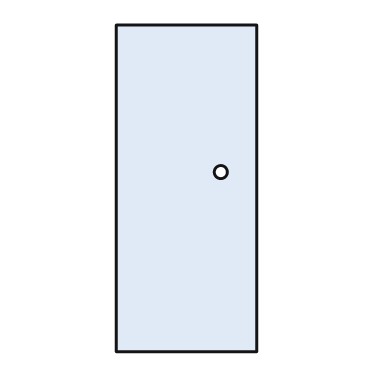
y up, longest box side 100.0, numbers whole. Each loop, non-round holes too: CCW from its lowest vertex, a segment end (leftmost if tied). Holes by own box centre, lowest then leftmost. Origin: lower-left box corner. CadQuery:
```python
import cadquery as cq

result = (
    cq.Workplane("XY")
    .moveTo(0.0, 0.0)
    .lineTo(43.0, 0.0)
    .lineTo(43.0, 100.0)
    .lineTo(0.0, 100.0)
    .close()
    .moveTo(32.0, 55.0)
    .circle(2.0)
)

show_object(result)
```